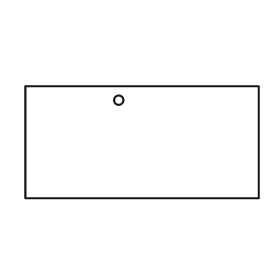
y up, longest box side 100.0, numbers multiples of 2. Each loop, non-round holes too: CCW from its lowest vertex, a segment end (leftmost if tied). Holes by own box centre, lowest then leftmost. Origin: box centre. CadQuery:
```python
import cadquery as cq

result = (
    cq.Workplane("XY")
    .moveTo(-50.0, -24.0)
    .lineTo(50.0, -24.0)
    .lineTo(50.0, 24.0)
    .lineTo(-50.0, 24.0)
    .close()
    .moveTo(-10.0, 18.0)
    .circle(2.0)
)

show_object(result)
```